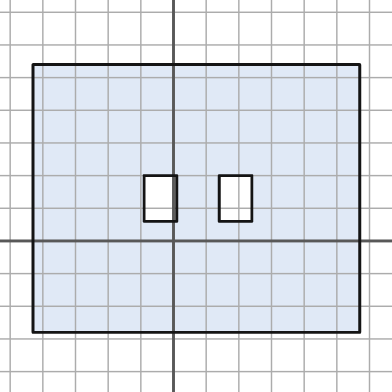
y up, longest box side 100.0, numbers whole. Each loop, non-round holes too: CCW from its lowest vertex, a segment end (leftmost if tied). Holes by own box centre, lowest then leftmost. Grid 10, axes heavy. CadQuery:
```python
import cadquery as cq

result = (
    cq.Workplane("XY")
    .moveTo(-43.0, -28.0)
    .lineTo(57.0, -28.0)
    .lineTo(57.0, 54.0)
    .lineTo(-43.0, 54.0)
    .close()
    .moveTo(-9.0, 6.0)
    .lineTo(1.0, 6.0)
    .lineTo(1.0, 20.0)
    .lineTo(-9.0, 20.0)
    .close()
    .moveTo(14.0, 6.0)
    .lineTo(24.0, 6.0)
    .lineTo(24.0, 20.0)
    .lineTo(14.0, 20.0)
    .close()
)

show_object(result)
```